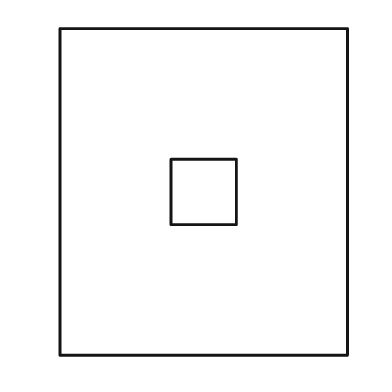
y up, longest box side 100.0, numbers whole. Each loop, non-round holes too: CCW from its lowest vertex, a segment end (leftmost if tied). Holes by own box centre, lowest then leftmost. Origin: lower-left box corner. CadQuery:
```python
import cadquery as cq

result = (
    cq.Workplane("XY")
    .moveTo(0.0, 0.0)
    .lineTo(88.0, 0.0)
    .lineTo(88.0, 100.0)
    .lineTo(0.0, 100.0)
    .close()
    .moveTo(34.0, 40.0)
    .lineTo(54.0, 40.0)
    .lineTo(54.0, 60.0)
    .lineTo(34.0, 60.0)
    .close()
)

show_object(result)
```